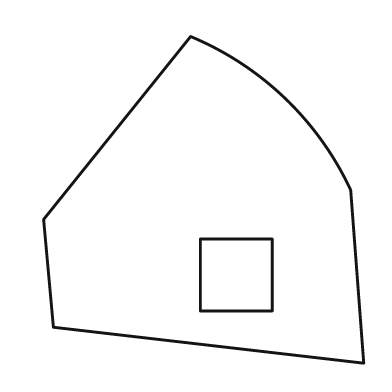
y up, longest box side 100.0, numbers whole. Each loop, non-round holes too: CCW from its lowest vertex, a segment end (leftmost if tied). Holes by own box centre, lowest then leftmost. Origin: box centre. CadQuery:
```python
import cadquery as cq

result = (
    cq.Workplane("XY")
    .moveTo(49.0, -50.0)
    .lineTo(45.0, 3.0)
    .threePointArc((25.0, 31.0), (-4.0, 50.0))
    .lineTo(-49.0, -6.0)
    .lineTo(-46.0, -39.0)
    .close()
    .moveTo(-1.0, -34.0)
    .lineTo(21.0, -34.0)
    .lineTo(21.0, -12.0)
    .lineTo(-1.0, -12.0)
    .close()
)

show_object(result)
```